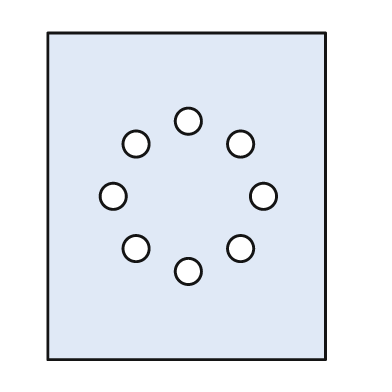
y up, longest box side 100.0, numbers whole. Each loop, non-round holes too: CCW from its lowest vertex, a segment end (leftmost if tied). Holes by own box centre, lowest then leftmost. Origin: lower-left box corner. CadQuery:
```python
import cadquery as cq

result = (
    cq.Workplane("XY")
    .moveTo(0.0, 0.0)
    .lineTo(85.0, 0.0)
    .lineTo(85.0, 100.0)
    .lineTo(0.0, 100.0)
    .close()
    .moveTo(43.0, 27.0)
    .circle(4.0)
    .moveTo(27.0, 34.0)
    .circle(4.0)
    .moveTo(59.0, 34.0)
    .circle(4.0)
    .moveTo(20.0, 50.0)
    .circle(4.0)
    .moveTo(66.0, 50.0)
    .circle(4.0)
    .moveTo(27.0, 66.0)
    .circle(4.0)
    .moveTo(59.0, 66.0)
    .circle(4.0)
    .moveTo(43.0, 73.0)
    .circle(4.0)
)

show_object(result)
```